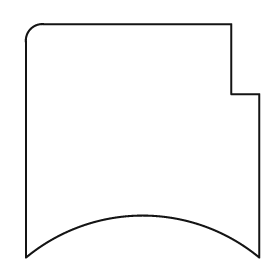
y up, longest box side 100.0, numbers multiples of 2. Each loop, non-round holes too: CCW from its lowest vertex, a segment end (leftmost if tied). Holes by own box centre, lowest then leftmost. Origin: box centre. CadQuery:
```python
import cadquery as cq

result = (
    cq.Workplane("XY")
    .moveTo(-50.0, -50.0)
    .threePointArc((0.0, -32.0), (50.0, -50.0))
    .lineTo(50.0, 20.0)
    .lineTo(38.0, 20.0)
    .lineTo(38.0, 50.0)
    .lineTo(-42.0, 50.0)
    .threePointArc((-48.0, 48.0), (-50.0, 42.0))
    .close()
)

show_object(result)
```